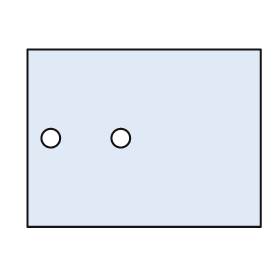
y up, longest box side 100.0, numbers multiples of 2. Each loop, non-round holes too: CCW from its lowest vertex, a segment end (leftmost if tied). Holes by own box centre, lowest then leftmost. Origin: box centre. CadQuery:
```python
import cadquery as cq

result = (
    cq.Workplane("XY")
    .moveTo(-50.0, -38.0)
    .lineTo(50.0, -38.0)
    .lineTo(50.0, 38.0)
    .lineTo(-50.0, 38.0)
    .close()
    .moveTo(-40.0, 0.0)
    .circle(4.0)
    .moveTo(-10.0, 0.0)
    .circle(4.0)
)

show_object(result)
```